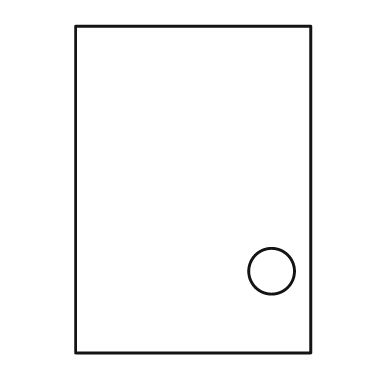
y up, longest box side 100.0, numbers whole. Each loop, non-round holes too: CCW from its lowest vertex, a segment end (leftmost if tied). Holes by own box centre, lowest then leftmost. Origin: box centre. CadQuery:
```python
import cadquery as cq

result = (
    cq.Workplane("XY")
    .moveTo(-36.0, -50.0)
    .lineTo(36.0, -50.0)
    .lineTo(36.0, 50.0)
    .lineTo(-36.0, 50.0)
    .close()
    .moveTo(24.0, -25.0)
    .circle(7.0)
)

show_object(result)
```